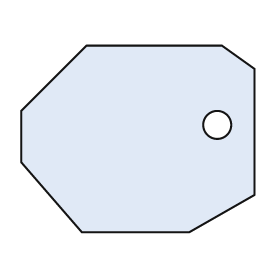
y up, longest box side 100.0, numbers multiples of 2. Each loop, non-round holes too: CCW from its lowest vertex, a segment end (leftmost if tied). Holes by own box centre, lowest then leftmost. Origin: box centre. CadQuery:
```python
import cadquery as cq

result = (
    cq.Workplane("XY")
    .moveTo(-24.0, -40.0)
    .lineTo(22.0, -40.0)
    .lineTo(50.0, -24.0)
    .lineTo(50.0, 30.0)
    .lineTo(36.0, 40.0)
    .lineTo(-22.0, 40.0)
    .lineTo(-50.0, 12.0)
    .lineTo(-50.0, -10.0)
    .close()
    .moveTo(34.0, 6.0)
    .circle(6.0)
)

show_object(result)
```